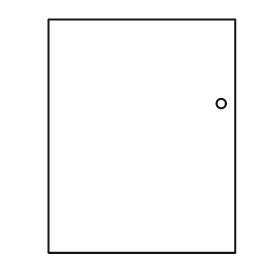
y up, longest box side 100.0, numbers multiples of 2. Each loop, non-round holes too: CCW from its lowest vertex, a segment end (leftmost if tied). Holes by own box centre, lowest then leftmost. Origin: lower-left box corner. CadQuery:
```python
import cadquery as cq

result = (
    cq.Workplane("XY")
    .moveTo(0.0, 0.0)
    .lineTo(80.0, 0.0)
    .lineTo(80.0, 100.0)
    .lineTo(0.0, 100.0)
    .close()
    .moveTo(74.0, 64.0)
    .circle(2.0)
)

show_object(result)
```